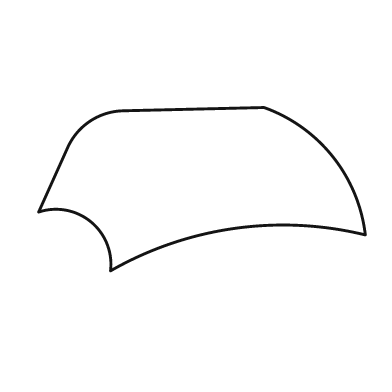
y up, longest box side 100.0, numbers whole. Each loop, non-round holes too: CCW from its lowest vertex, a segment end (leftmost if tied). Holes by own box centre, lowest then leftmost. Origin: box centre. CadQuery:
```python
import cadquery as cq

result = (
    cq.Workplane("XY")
    .moveTo(-28.0, -25.0)
    .threePointArc((10.0, -12.0), (50.0, -14.0))
    .threePointArc((40.0, 10.0), (19.0, 25.0))
    .lineTo(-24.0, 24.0)
    .threePointArc((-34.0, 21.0), (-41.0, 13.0))
    .lineTo(-50.0, -7.0)
    .threePointArc((-34.0, -10.0), (-28.0, -25.0))
    .close()
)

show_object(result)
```